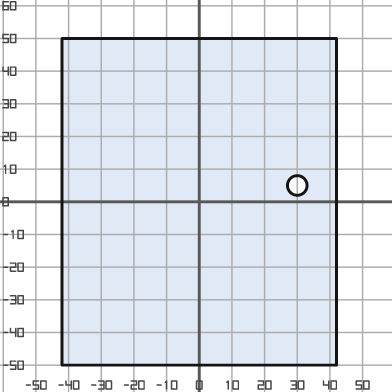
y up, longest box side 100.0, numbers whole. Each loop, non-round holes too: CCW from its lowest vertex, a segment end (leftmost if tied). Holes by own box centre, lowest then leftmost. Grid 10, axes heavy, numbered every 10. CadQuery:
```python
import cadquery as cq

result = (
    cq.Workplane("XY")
    .moveTo(-42.0, -50.0)
    .lineTo(42.0, -50.0)
    .lineTo(42.0, 50.0)
    .lineTo(-42.0, 50.0)
    .close()
    .moveTo(30.0, 5.0)
    .circle(3.0)
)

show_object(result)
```